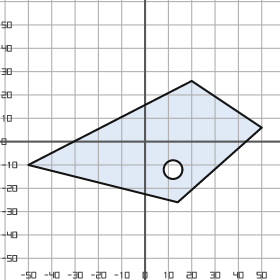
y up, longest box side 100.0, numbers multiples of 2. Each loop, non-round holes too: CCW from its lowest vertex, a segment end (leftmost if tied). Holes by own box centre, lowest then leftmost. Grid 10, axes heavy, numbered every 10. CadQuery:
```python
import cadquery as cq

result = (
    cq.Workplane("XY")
    .moveTo(14.0, -26.0)
    .lineTo(50.0, 6.0)
    .lineTo(20.0, 26.0)
    .lineTo(-50.0, -10.0)
    .close()
    .moveTo(12.0, -12.0)
    .circle(4.0)
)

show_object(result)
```